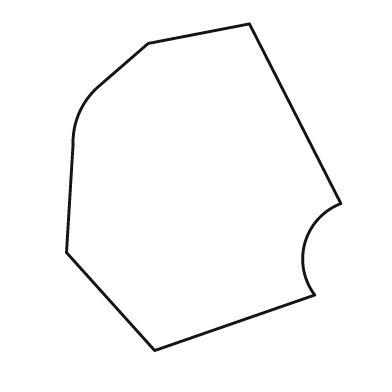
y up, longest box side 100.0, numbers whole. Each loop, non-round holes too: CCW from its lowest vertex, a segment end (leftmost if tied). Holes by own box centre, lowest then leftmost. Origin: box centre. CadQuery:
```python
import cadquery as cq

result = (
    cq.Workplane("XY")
    .moveTo(-15.0, -50.0)
    .lineTo(34.0, -33.0)
    .threePointArc((31.0, -17.0), (42.0, -5.0))
    .lineTo(14.0, 50.0)
    .lineTo(-17.0, 44.0)
    .lineTo(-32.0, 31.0)
    .threePointArc((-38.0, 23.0), (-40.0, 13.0))
    .lineTo(-42.0, -20.0)
    .close()
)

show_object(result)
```